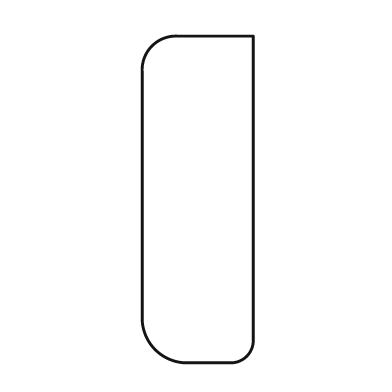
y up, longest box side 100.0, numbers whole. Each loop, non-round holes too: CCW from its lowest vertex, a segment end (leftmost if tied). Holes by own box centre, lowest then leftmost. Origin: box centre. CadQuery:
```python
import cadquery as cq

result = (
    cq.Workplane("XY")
    .moveTo(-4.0, -50.0)
    .lineTo(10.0, -50.0)
    .threePointArc((15.0, -48.0), (17.0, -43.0))
    .lineTo(17.0, 50.0)
    .lineTo(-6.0, 50.0)
    .threePointArc((-14.0, 47.0), (-17.0, 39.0))
    .lineTo(-17.0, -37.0)
    .threePointArc((-13.0, -46.0), (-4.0, -50.0))
    .close()
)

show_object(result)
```